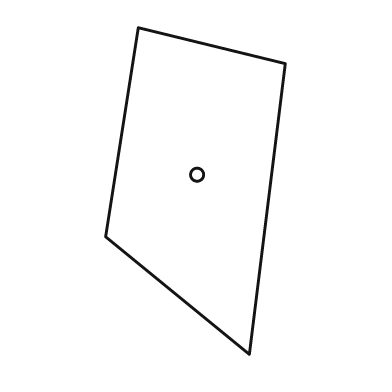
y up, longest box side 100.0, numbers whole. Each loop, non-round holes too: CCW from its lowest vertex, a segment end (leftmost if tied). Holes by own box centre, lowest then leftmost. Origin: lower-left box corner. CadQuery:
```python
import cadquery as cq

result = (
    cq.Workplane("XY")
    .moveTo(44.0, 0.0)
    .lineTo(55.0, 89.0)
    .lineTo(10.0, 100.0)
    .lineTo(0.0, 36.0)
    .close()
    .moveTo(28.0, 55.0)
    .circle(2.0)
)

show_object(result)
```